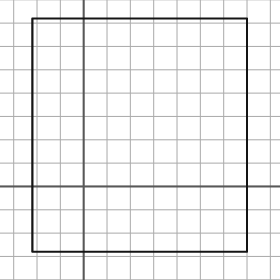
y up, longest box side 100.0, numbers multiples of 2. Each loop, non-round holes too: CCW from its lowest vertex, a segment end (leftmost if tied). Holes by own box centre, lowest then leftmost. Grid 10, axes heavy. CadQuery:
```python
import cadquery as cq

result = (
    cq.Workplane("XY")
    .moveTo(-22.0, -28.0)
    .lineTo(70.0, -28.0)
    .lineTo(70.0, 72.0)
    .lineTo(-22.0, 72.0)
    .close()
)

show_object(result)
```